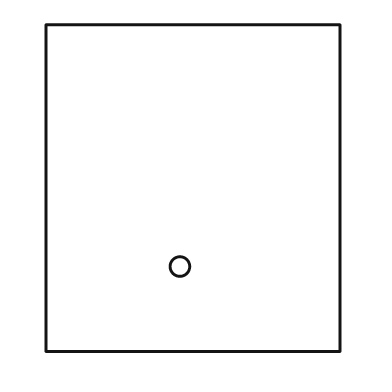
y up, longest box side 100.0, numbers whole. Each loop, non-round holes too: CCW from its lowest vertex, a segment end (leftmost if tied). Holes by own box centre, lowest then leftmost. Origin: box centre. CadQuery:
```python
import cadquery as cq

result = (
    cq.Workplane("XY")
    .moveTo(-45.0, -50.0)
    .lineTo(45.0, -50.0)
    .lineTo(45.0, 50.0)
    .lineTo(-45.0, 50.0)
    .close()
    .moveTo(-4.0, -24.0)
    .circle(3.0)
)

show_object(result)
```